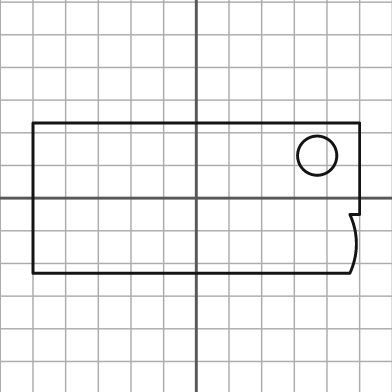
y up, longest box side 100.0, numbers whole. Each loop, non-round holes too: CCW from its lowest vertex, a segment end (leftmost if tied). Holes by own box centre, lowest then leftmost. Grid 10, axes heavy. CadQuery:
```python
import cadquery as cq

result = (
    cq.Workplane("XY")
    .moveTo(-50.0, -23.0)
    .lineTo(47.0, -23.0)
    .threePointArc((49.0, -14.0), (47.0, -5.0))
    .lineTo(50.0, -5.0)
    .lineTo(50.0, 23.0)
    .lineTo(-50.0, 23.0)
    .close()
    .moveTo(37.0, 13.0)
    .circle(6.0)
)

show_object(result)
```